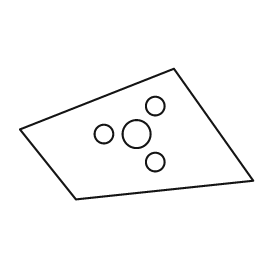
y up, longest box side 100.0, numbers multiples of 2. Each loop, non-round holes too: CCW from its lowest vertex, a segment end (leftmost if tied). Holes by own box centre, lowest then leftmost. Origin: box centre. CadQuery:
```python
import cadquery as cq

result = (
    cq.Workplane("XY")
    .moveTo(-26.0, -28.0)
    .lineTo(50.0, -20.0)
    .lineTo(16.0, 28.0)
    .lineTo(-50.0, 2.0)
    .close()
    .moveTo(8.0, -12.0)
    .circle(4.0)
    .moveTo(-14.0, 0.0)
    .circle(4.0)
    .moveTo(0.0, 0.0)
    .circle(6.0)
    .moveTo(8.0, 12.0)
    .circle(4.0)
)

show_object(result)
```